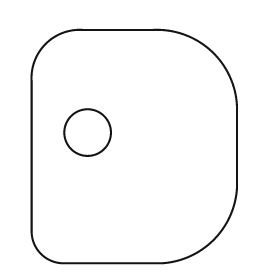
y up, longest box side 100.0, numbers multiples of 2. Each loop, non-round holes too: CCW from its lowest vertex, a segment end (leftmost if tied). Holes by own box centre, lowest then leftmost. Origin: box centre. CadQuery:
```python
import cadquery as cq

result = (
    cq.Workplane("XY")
    .moveTo(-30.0, -50.0)
    .lineTo(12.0, -50.0)
    .threePointArc((34.0, -40.0), (44.0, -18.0))
    .lineTo(44.0, 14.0)
    .threePointArc((34.0, 40.0), (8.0, 50.0))
    .lineTo(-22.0, 50.0)
    .threePointArc((-38.0, 44.0), (-44.0, 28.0))
    .lineTo(-44.0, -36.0)
    .threePointArc((-40.0, -46.0), (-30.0, -50.0))
    .close()
    .moveTo(-20.0, 6.0)
    .circle(10.0)
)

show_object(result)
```